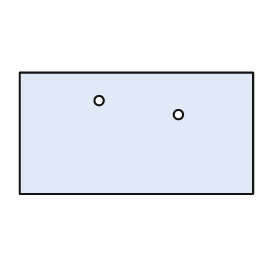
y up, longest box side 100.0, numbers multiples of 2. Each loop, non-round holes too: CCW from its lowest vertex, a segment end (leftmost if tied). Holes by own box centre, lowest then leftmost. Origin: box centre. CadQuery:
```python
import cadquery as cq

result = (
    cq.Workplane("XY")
    .moveTo(-50.0, -26.0)
    .lineTo(50.0, -26.0)
    .lineTo(50.0, 26.0)
    .lineTo(-50.0, 26.0)
    .close()
    .moveTo(18.0, 8.0)
    .circle(2.0)
    .moveTo(-16.0, 14.0)
    .circle(2.0)
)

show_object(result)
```